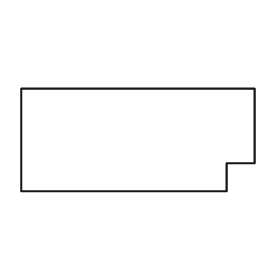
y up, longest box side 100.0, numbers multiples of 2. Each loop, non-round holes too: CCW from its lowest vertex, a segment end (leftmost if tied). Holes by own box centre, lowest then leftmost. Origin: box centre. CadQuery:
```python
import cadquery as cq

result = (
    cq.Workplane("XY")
    .moveTo(-50.0, -22.0)
    .lineTo(38.0, -22.0)
    .lineTo(38.0, -10.0)
    .lineTo(50.0, -10.0)
    .lineTo(50.0, 22.0)
    .lineTo(-50.0, 22.0)
    .close()
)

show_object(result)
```